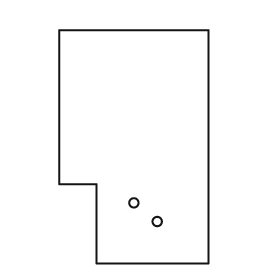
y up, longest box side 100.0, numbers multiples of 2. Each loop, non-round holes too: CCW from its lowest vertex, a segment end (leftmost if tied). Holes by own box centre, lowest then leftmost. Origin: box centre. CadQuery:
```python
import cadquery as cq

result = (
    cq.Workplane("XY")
    .moveTo(-16.0, -50.0)
    .lineTo(32.0, -50.0)
    .lineTo(32.0, 50.0)
    .lineTo(-32.0, 50.0)
    .lineTo(-32.0, -16.0)
    .lineTo(-16.0, -16.0)
    .close()
    .moveTo(10.0, -32.0)
    .circle(2.0)
    .moveTo(0.0, -24.0)
    .circle(2.0)
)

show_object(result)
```